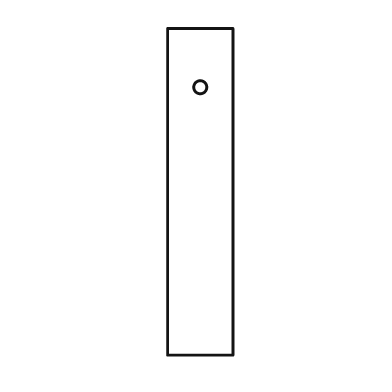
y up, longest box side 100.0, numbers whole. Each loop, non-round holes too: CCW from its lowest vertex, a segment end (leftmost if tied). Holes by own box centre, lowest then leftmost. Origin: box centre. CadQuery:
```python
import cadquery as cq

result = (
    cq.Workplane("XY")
    .moveTo(-10.0, -50.0)
    .lineTo(10.0, -50.0)
    .lineTo(10.0, 50.0)
    .lineTo(-10.0, 50.0)
    .close()
    .moveTo(0.0, 32.0)
    .circle(2.0)
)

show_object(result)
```